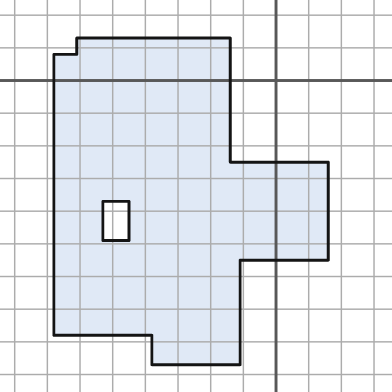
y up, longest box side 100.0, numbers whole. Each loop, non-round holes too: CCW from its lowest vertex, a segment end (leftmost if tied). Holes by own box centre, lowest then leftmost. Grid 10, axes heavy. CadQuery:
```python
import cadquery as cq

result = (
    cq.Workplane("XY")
    .moveTo(-38.0, -87.0)
    .lineTo(-11.0, -87.0)
    .lineTo(-11.0, -55.0)
    .lineTo(16.0, -55.0)
    .lineTo(16.0, -25.0)
    .lineTo(-14.0, -25.0)
    .lineTo(-14.0, 13.0)
    .lineTo(-61.0, 13.0)
    .lineTo(-61.0, 8.0)
    .lineTo(-68.0, 8.0)
    .lineTo(-68.0, -78.0)
    .lineTo(-38.0, -78.0)
    .close()
    .moveTo(-53.0, -49.0)
    .lineTo(-45.0, -49.0)
    .lineTo(-45.0, -37.0)
    .lineTo(-53.0, -37.0)
    .close()
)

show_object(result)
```